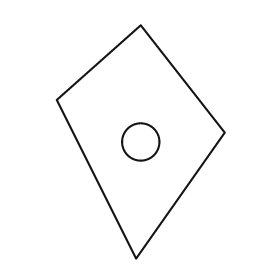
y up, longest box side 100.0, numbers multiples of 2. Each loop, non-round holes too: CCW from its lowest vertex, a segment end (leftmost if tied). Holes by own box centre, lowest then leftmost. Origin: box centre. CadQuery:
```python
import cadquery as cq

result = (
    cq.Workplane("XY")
    .moveTo(-2.0, -50.0)
    .lineTo(36.0, 4.0)
    .lineTo(0.0, 50.0)
    .lineTo(-36.0, 18.0)
    .close()
    .moveTo(0.0, 0.0)
    .circle(8.0)
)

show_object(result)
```